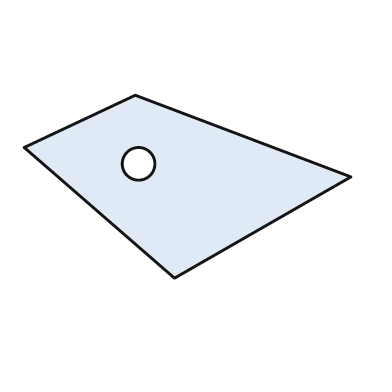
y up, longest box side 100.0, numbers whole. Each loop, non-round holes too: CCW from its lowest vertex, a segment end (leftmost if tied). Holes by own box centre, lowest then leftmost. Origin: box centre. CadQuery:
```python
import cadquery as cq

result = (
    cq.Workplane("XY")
    .moveTo(-4.0, -28.0)
    .lineTo(50.0, 3.0)
    .lineTo(-16.0, 28.0)
    .lineTo(-50.0, 12.0)
    .close()
    .moveTo(-15.0, 7.0)
    .circle(5.0)
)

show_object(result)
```